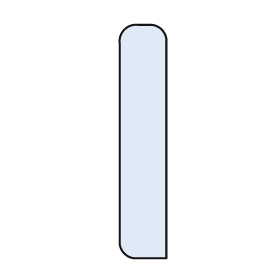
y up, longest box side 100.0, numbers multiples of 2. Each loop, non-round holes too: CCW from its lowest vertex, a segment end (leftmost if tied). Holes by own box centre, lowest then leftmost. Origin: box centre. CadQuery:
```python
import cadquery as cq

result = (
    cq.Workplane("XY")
    .moveTo(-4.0, -50.0)
    .lineTo(10.0, -50.0)
    .lineTo(10.0, 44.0)
    .threePointArc((8.0, 48.0), (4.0, 50.0))
    .lineTo(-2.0, 50.0)
    .threePointArc((-8.0, 48.0), (-10.0, 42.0))
    .lineTo(-10.0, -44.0)
    .threePointArc((-8.0, -48.0), (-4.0, -50.0))
    .close()
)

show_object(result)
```